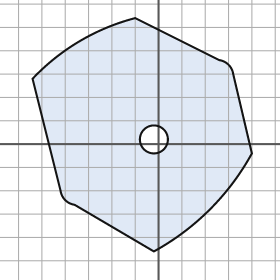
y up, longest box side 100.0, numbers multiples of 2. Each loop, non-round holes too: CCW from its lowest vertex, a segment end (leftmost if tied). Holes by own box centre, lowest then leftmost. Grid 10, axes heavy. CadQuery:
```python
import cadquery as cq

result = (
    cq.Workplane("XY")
    .moveTo(-2.0, -46.0)
    .threePointArc((22.0, -28.0), (40.0, -4.0))
    .lineTo(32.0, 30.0)
    .threePointArc((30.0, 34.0), (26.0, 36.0))
    .lineTo(-10.0, 54.0)
    .threePointArc((-34.0, 44.0), (-54.0, 28.0))
    .lineTo(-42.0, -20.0)
    .threePointArc((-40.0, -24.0), (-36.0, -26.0))
    .close()
    .moveTo(-2.0, 2.0)
    .circle(6.0)
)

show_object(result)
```